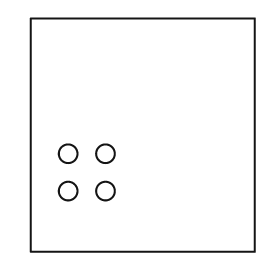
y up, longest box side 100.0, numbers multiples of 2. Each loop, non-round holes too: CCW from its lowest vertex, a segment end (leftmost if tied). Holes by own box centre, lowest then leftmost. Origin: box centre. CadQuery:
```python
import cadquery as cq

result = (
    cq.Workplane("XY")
    .moveTo(-48.0, -50.0)
    .lineTo(48.0, -50.0)
    .lineTo(48.0, 50.0)
    .lineTo(-48.0, 50.0)
    .close()
    .moveTo(-32.0, -24.0)
    .circle(4.0)
    .moveTo(-16.0, -24.0)
    .circle(4.0)
    .moveTo(-32.0, -8.0)
    .circle(4.0)
    .moveTo(-16.0, -8.0)
    .circle(4.0)
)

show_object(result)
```